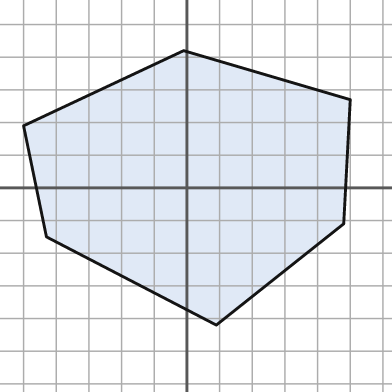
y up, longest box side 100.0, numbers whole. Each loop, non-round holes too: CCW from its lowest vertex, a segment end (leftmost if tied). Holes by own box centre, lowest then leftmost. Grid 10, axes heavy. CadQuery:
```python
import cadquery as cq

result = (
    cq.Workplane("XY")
    .moveTo(9.0, -42.0)
    .lineTo(48.0, -11.0)
    .lineTo(50.0, 27.0)
    .lineTo(-1.0, 42.0)
    .lineTo(-50.0, 19.0)
    .lineTo(-43.0, -15.0)
    .close()
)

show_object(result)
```